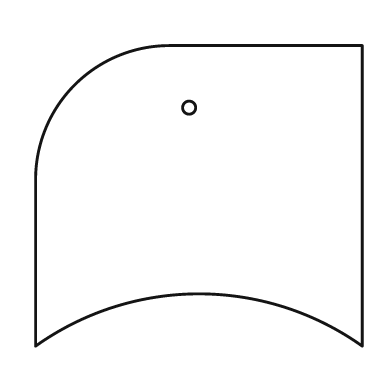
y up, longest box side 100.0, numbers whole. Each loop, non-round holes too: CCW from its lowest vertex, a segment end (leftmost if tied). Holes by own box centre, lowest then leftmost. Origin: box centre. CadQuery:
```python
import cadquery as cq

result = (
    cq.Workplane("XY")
    .moveTo(-50.0, -46.0)
    .threePointArc((0.0, -30.0), (50.0, -46.0))
    .lineTo(50.0, 46.0)
    .lineTo(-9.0, 46.0)
    .threePointArc((-38.0, 34.0), (-50.0, 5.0))
    .close()
    .moveTo(-3.0, 27.0)
    .circle(2.0)
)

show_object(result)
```